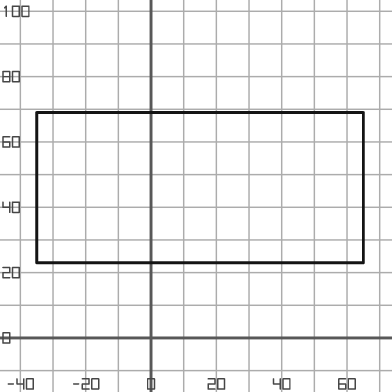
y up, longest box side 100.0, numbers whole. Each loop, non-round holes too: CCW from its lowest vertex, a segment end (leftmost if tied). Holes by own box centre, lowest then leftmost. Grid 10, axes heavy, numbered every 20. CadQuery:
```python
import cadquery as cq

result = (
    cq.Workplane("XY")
    .moveTo(-35.0, 23.0)
    .lineTo(65.0, 23.0)
    .lineTo(65.0, 69.0)
    .lineTo(-35.0, 69.0)
    .close()
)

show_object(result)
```